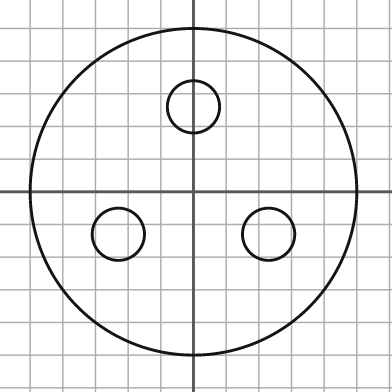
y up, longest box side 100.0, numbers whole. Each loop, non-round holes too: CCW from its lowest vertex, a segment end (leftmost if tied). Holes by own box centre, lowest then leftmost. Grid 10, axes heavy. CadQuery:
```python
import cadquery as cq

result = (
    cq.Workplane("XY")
    .moveTo(0.0, 0.0)
    .circle(50.0)
    .moveTo(-23.0, -13.0)
    .circle(8.0)
    .moveTo(23.0, -13.0)
    .circle(8.0)
    .moveTo(0.0, 26.0)
    .circle(8.0)
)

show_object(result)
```